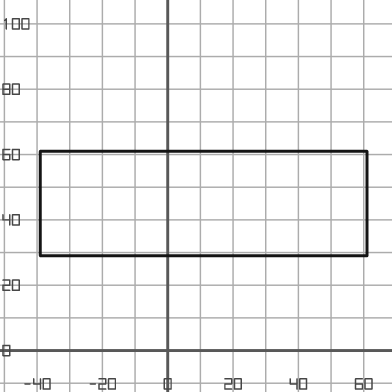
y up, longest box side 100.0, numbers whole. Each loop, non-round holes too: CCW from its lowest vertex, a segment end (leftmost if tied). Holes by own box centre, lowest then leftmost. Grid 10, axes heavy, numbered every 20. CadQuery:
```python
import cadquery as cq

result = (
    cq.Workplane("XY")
    .moveTo(-39.0, 29.0)
    .lineTo(61.0, 29.0)
    .lineTo(61.0, 61.0)
    .lineTo(-39.0, 61.0)
    .close()
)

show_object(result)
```